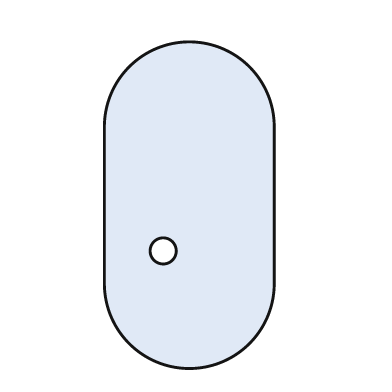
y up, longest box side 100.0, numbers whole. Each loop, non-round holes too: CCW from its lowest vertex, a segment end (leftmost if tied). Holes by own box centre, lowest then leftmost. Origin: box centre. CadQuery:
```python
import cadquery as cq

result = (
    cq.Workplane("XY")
    .moveTo(-26.0, -24.0)
    .threePointArc((0.0, -50.0), (26.0, -24.0))
    .lineTo(26.0, 24.0)
    .threePointArc((0.0, 50.0), (-26.0, 24.0))
    .close()
    .moveTo(-8.0, -14.0)
    .circle(4.0)
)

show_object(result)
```